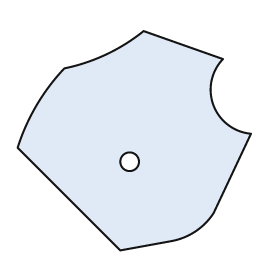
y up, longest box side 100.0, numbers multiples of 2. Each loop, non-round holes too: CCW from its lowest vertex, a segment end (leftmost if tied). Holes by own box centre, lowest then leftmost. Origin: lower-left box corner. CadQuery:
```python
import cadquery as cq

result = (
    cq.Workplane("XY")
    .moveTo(44.0, 0.0)
    .lineTo(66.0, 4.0)
    .threePointArc((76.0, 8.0), (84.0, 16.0))
    .lineTo(100.0, 50.0)
    .threePointArc((84.0, 62.0), (88.0, 82.0))
    .lineTo(54.0, 94.0)
    .threePointArc((38.0, 84.0), (20.0, 78.0))
    .threePointArc((8.0, 62.0), (0.0, 44.0))
    .close()
    .moveTo(48.0, 38.0)
    .circle(4.0)
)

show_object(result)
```